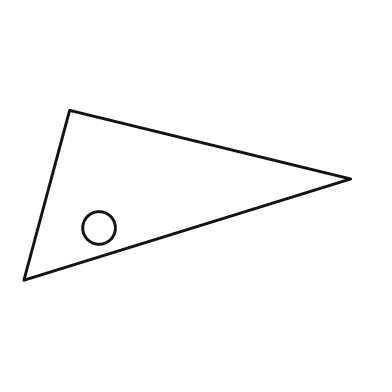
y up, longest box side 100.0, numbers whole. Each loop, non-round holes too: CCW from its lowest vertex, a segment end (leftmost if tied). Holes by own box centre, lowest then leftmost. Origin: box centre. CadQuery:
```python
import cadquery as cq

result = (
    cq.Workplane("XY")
    .moveTo(-50.0, -26.0)
    .lineTo(50.0, 5.0)
    .lineTo(-36.0, 26.0)
    .close()
    .moveTo(-27.0, -10.0)
    .circle(5.0)
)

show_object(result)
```